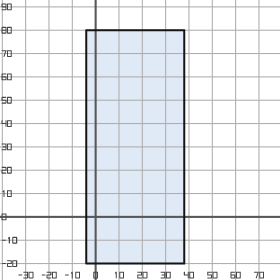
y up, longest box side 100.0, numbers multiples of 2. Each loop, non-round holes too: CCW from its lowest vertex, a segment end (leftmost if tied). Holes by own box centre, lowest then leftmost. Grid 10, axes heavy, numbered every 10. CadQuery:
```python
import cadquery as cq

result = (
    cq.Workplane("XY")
    .moveTo(-4.0, -20.0)
    .lineTo(38.0, -20.0)
    .lineTo(38.0, 80.0)
    .lineTo(-4.0, 80.0)
    .close()
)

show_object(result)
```